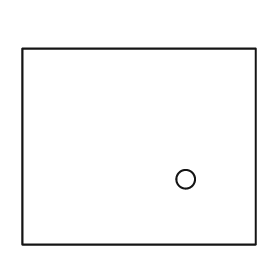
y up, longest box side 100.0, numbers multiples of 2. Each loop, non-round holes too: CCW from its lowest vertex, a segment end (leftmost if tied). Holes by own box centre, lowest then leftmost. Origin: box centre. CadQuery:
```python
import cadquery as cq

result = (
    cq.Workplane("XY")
    .moveTo(-50.0, -42.0)
    .lineTo(50.0, -42.0)
    .lineTo(50.0, 42.0)
    .lineTo(-50.0, 42.0)
    .close()
    .moveTo(20.0, -14.0)
    .circle(4.0)
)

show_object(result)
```